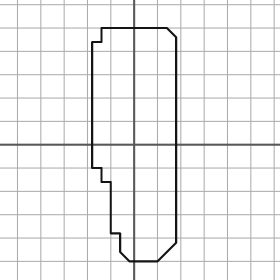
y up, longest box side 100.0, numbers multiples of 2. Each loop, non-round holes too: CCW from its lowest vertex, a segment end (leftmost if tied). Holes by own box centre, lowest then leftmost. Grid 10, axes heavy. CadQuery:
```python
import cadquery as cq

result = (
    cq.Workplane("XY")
    .moveTo(-2.0, -50.0)
    .lineTo(10.0, -50.0)
    .lineTo(18.0, -42.0)
    .lineTo(18.0, 46.0)
    .lineTo(14.0, 50.0)
    .lineTo(-14.0, 50.0)
    .lineTo(-14.0, 44.0)
    .lineTo(-18.0, 44.0)
    .lineTo(-18.0, -10.0)
    .lineTo(-14.0, -10.0)
    .lineTo(-14.0, -16.0)
    .lineTo(-10.0, -16.0)
    .lineTo(-10.0, -38.0)
    .lineTo(-6.0, -38.0)
    .lineTo(-6.0, -46.0)
    .close()
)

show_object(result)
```